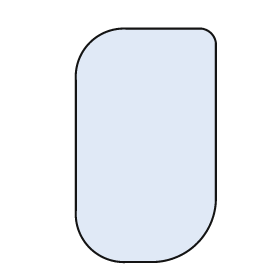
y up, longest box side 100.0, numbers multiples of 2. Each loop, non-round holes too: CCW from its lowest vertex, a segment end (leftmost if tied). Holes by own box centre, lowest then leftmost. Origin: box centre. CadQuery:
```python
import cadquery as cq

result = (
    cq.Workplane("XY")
    .moveTo(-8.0, -50.0)
    .lineTo(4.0, -50.0)
    .threePointArc((22.0, -42.0), (30.0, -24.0))
    .lineTo(30.0, 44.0)
    .threePointArc((28.0, 48.0), (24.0, 50.0))
    .lineTo(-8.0, 50.0)
    .threePointArc((-24.0, 44.0), (-30.0, 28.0))
    .lineTo(-30.0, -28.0)
    .threePointArc((-24.0, -44.0), (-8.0, -50.0))
    .close()
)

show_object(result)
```